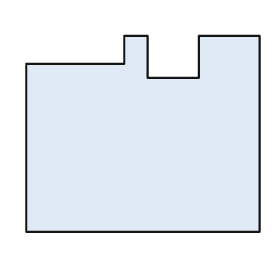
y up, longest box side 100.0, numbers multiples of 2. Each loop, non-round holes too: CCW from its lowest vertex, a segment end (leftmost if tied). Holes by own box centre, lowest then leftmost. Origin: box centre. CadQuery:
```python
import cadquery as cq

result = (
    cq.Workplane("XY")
    .moveTo(-50.0, -42.0)
    .lineTo(50.0, -42.0)
    .lineTo(50.0, 42.0)
    .lineTo(24.0, 42.0)
    .lineTo(24.0, 24.0)
    .lineTo(2.0, 24.0)
    .lineTo(2.0, 42.0)
    .lineTo(-8.0, 42.0)
    .lineTo(-8.0, 30.0)
    .lineTo(-50.0, 30.0)
    .close()
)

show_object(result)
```